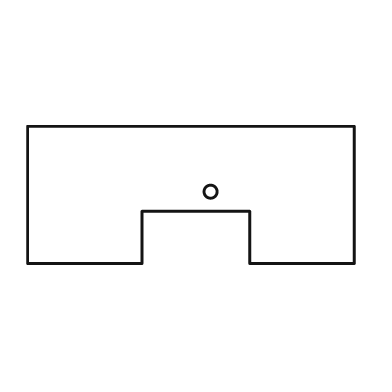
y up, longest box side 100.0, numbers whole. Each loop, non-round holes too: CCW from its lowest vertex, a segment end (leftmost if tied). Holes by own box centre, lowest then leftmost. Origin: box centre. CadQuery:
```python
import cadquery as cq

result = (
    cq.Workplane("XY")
    .moveTo(-50.0, -21.0)
    .lineTo(-15.0, -21.0)
    .lineTo(-15.0, -5.0)
    .lineTo(18.0, -5.0)
    .lineTo(18.0, -21.0)
    .lineTo(50.0, -21.0)
    .lineTo(50.0, 21.0)
    .lineTo(-50.0, 21.0)
    .close()
    .moveTo(6.0, 1.0)
    .circle(2.0)
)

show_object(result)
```